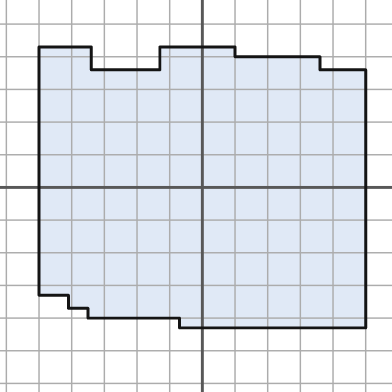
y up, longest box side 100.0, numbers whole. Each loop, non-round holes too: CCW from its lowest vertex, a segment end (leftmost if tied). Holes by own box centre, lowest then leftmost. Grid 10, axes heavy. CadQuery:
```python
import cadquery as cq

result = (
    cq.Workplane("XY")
    .moveTo(-7.0, -43.0)
    .lineTo(50.0, -43.0)
    .lineTo(50.0, 36.0)
    .lineTo(36.0, 36.0)
    .lineTo(36.0, 40.0)
    .lineTo(10.0, 40.0)
    .lineTo(10.0, 43.0)
    .lineTo(-13.0, 43.0)
    .lineTo(-13.0, 36.0)
    .lineTo(-34.0, 36.0)
    .lineTo(-34.0, 43.0)
    .lineTo(-50.0, 43.0)
    .lineTo(-50.0, -33.0)
    .lineTo(-41.0, -33.0)
    .lineTo(-41.0, -37.0)
    .lineTo(-35.0, -37.0)
    .lineTo(-35.0, -40.0)
    .lineTo(-7.0, -40.0)
    .close()
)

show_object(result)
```